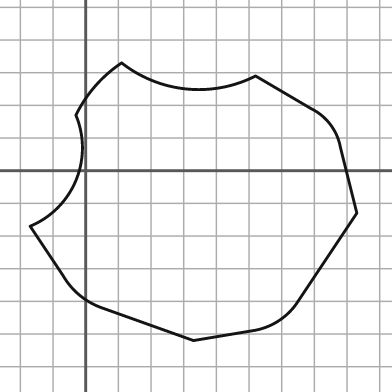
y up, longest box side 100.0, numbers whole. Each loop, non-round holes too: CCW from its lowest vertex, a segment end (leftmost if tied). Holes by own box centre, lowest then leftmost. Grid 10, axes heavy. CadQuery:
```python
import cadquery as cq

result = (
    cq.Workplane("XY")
    .moveTo(33.0, -52.0)
    .lineTo(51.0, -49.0)
    .threePointArc((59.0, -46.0), (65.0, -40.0))
    .lineTo(83.0, -13.0)
    .lineTo(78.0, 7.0)
    .threePointArc((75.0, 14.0), (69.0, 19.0))
    .lineTo(52.0, 29.0)
    .threePointArc((31.0, 25.0), (11.0, 33.0))
    .threePointArc((3.0, 26.0), (-3.0, 17.0))
    .threePointArc((-3.0, -3.0), (-17.0, -17.0))
    .lineTo(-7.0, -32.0)
    .threePointArc((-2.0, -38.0), (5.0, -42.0))
    .close()
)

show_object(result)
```